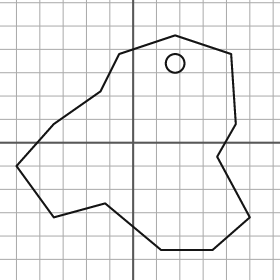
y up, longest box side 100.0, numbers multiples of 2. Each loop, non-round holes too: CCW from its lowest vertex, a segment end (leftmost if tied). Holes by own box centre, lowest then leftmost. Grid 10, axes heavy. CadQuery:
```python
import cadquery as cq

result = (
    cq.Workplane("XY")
    .moveTo(12.0, -46.0)
    .lineTo(34.0, -46.0)
    .lineTo(50.0, -32.0)
    .lineTo(36.0, -6.0)
    .lineTo(44.0, 8.0)
    .lineTo(42.0, 38.0)
    .lineTo(18.0, 46.0)
    .lineTo(-6.0, 38.0)
    .lineTo(-14.0, 22.0)
    .lineTo(-34.0, 8.0)
    .lineTo(-50.0, -10.0)
    .lineTo(-34.0, -32.0)
    .lineTo(-12.0, -26.0)
    .close()
    .moveTo(18.0, 34.0)
    .circle(4.0)
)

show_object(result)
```